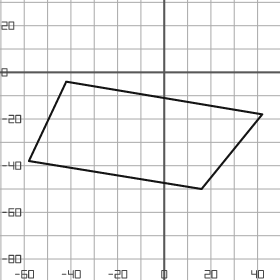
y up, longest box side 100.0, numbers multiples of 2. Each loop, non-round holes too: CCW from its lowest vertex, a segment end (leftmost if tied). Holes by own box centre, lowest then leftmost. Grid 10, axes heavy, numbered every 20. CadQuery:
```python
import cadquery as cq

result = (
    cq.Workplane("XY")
    .moveTo(16.0, -50.0)
    .lineTo(42.0, -18.0)
    .lineTo(-42.0, -4.0)
    .lineTo(-58.0, -38.0)
    .close()
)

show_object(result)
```